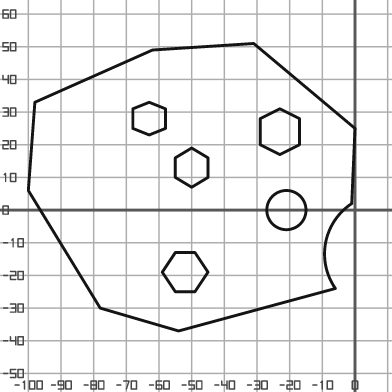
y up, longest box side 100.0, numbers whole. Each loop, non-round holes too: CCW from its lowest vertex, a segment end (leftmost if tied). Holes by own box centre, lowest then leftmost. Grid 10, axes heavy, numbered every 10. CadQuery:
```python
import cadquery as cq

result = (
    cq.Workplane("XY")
    .moveTo(-54.0, -37.0)
    .lineTo(-6.0, -24.0)
    .threePointArc((-9.0, -10.0), (-1.0, 2.0))
    .lineTo(0.0, 25.0)
    .lineTo(-31.0, 51.0)
    .lineTo(-62.0, 49.0)
    .lineTo(-98.0, 33.0)
    .lineTo(-100.0, 6.0)
    .lineTo(-78.0, -30.0)
    .close()
    .moveTo(-55.0, -25.0)
    .lineTo(-49.0, -25.0)
    .lineTo(-45.0, -19.0)
    .lineTo(-49.0, -13.0)
    .lineTo(-55.0, -13.0)
    .lineTo(-59.0, -19.0)
    .close()
    .moveTo(-21.0, 0.0)
    .circle(6.0)
    .moveTo(-50.0, 7.0)
    .lineTo(-45.0, 10.0)
    .lineTo(-45.0, 16.0)
    .lineTo(-50.0, 19.0)
    .lineTo(-55.0, 16.0)
    .lineTo(-55.0, 10.0)
    .close()
    .moveTo(-23.0, 17.0)
    .lineTo(-17.0, 20.0)
    .lineTo(-17.0, 28.0)
    .lineTo(-23.0, 31.0)
    .lineTo(-29.0, 28.0)
    .lineTo(-29.0, 20.0)
    .close()
    .moveTo(-63.0, 23.0)
    .lineTo(-58.0, 25.0)
    .lineTo(-58.0, 31.0)
    .lineTo(-63.0, 33.0)
    .lineTo(-68.0, 31.0)
    .lineTo(-68.0, 25.0)
    .close()
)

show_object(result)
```